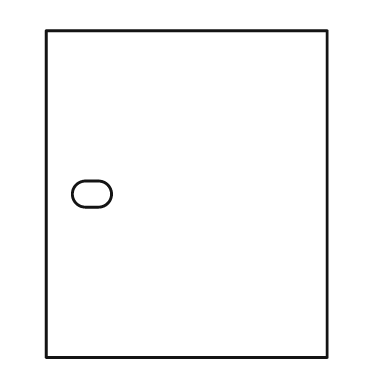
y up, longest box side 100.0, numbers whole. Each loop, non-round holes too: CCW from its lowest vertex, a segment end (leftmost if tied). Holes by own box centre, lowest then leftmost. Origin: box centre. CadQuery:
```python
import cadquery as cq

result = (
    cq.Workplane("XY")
    .moveTo(-43.0, -50.0)
    .lineTo(43.0, -50.0)
    .lineTo(43.0, 50.0)
    .lineTo(-43.0, 50.0)
    .close()
    .moveTo(-31.0, -4.0)
    .lineTo(-27.0, -4.0)
    .threePointArc((-23.0, 0.0), (-27.0, 4.0))
    .lineTo(-31.0, 4.0)
    .threePointArc((-35.0, 0.0), (-31.0, -4.0))
    .close()
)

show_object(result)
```